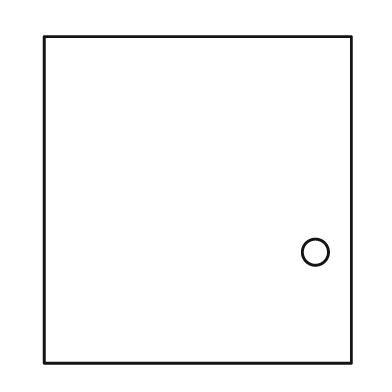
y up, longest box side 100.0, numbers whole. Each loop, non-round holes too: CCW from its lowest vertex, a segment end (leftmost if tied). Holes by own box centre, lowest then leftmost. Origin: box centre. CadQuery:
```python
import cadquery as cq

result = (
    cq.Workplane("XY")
    .moveTo(-47.0, -50.0)
    .lineTo(47.0, -50.0)
    .lineTo(47.0, 50.0)
    .lineTo(-47.0, 50.0)
    .close()
    .moveTo(36.0, -16.0)
    .circle(4.0)
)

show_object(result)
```